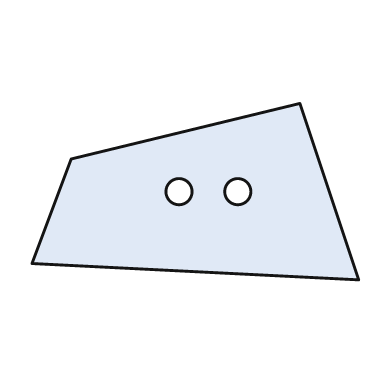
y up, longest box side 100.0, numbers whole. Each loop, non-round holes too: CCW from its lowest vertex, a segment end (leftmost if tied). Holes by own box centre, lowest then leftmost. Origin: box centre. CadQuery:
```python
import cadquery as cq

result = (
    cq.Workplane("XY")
    .moveTo(50.0, -27.0)
    .lineTo(32.0, 27.0)
    .lineTo(-38.0, 10.0)
    .lineTo(-50.0, -22.0)
    .close()
    .moveTo(-5.0, 0.0)
    .circle(4.0)
    .moveTo(13.0, 0.0)
    .circle(4.0)
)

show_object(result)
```